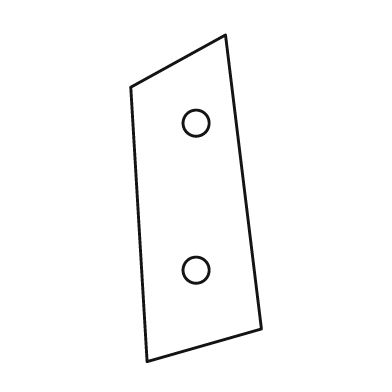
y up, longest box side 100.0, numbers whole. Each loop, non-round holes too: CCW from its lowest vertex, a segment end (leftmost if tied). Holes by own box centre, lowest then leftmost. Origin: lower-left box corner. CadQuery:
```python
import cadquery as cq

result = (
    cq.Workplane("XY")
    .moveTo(5.0, 0.0)
    .lineTo(40.0, 10.0)
    .lineTo(29.0, 100.0)
    .lineTo(0.0, 84.0)
    .close()
    .moveTo(20.0, 28.0)
    .circle(4.0)
    .moveTo(20.0, 73.0)
    .circle(4.0)
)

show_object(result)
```